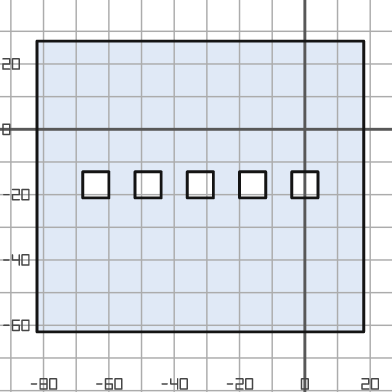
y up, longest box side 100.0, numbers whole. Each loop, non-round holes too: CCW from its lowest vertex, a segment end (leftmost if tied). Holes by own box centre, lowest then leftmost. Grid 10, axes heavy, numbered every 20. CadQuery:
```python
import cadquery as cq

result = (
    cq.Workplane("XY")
    .moveTo(-82.0, -62.0)
    .lineTo(18.0, -62.0)
    .lineTo(18.0, 27.0)
    .lineTo(-82.0, 27.0)
    .close()
    .moveTo(-68.0, -21.0)
    .lineTo(-60.0, -21.0)
    .lineTo(-60.0, -13.0)
    .lineTo(-68.0, -13.0)
    .close()
    .moveTo(-52.0, -21.0)
    .lineTo(-44.0, -21.0)
    .lineTo(-44.0, -13.0)
    .lineTo(-52.0, -13.0)
    .close()
    .moveTo(-36.0, -21.0)
    .lineTo(-28.0, -21.0)
    .lineTo(-28.0, -13.0)
    .lineTo(-36.0, -13.0)
    .close()
    .moveTo(-20.0, -21.0)
    .lineTo(-12.0, -21.0)
    .lineTo(-12.0, -13.0)
    .lineTo(-20.0, -13.0)
    .close()
    .moveTo(-4.0, -21.0)
    .lineTo(4.0, -21.0)
    .lineTo(4.0, -13.0)
    .lineTo(-4.0, -13.0)
    .close()
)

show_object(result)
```